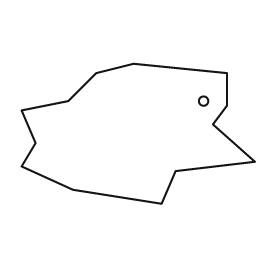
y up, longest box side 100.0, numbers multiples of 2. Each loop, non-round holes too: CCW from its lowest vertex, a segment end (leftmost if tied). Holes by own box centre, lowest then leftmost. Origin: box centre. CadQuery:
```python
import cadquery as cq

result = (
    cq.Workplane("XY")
    .moveTo(10.0, -30.0)
    .lineTo(16.0, -16.0)
    .lineTo(50.0, -12.0)
    .lineTo(32.0, 4.0)
    .lineTo(38.0, 12.0)
    .lineTo(38.0, 26.0)
    .lineTo(-2.0, 30.0)
    .lineTo(-18.0, 26.0)
    .lineTo(-30.0, 14.0)
    .lineTo(-50.0, 10.0)
    .lineTo(-44.0, -4.0)
    .lineTo(-50.0, -14.0)
    .lineTo(-28.0, -24.0)
    .close()
    .moveTo(28.0, 14.0)
    .circle(2.0)
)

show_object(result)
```